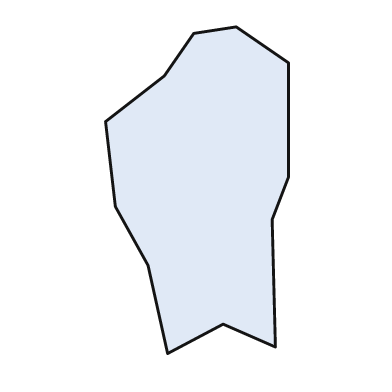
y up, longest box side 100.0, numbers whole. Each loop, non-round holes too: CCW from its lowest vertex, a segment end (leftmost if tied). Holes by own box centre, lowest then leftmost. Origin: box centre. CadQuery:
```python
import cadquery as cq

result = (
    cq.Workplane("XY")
    .moveTo(-9.0, -50.0)
    .lineTo(8.0, -41.0)
    .lineTo(24.0, -48.0)
    .lineTo(23.0, -9.0)
    .lineTo(28.0, 4.0)
    .lineTo(28.0, 39.0)
    .lineTo(12.0, 50.0)
    .lineTo(-1.0, 48.0)
    .lineTo(-10.0, 35.0)
    .lineTo(-28.0, 21.0)
    .lineTo(-25.0, -5.0)
    .lineTo(-15.0, -23.0)
    .close()
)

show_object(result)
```